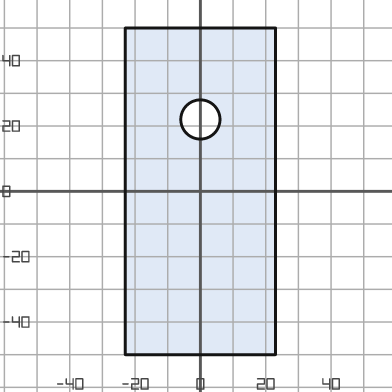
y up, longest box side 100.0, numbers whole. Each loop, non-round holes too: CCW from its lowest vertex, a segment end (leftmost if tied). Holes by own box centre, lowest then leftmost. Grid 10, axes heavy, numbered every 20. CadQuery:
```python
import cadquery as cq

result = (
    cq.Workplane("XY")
    .moveTo(-23.0, -50.0)
    .lineTo(23.0, -50.0)
    .lineTo(23.0, 50.0)
    .lineTo(-23.0, 50.0)
    .close()
    .moveTo(0.0, 22.0)
    .circle(6.0)
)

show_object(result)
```